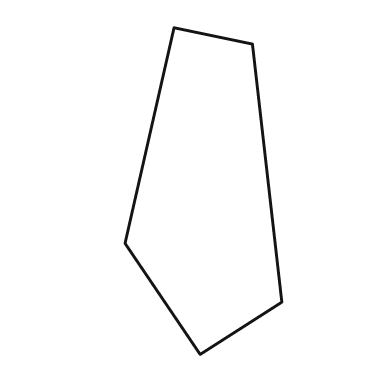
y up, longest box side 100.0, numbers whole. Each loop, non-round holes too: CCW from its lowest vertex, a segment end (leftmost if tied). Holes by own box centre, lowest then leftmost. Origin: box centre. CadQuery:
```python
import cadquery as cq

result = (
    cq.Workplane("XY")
    .moveTo(-1.0, -50.0)
    .lineTo(24.0, -34.0)
    .lineTo(15.0, 45.0)
    .lineTo(-9.0, 50.0)
    .lineTo(-24.0, -16.0)
    .close()
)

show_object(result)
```